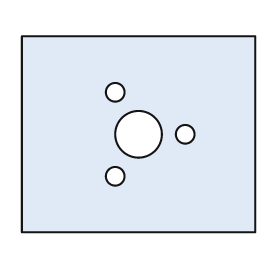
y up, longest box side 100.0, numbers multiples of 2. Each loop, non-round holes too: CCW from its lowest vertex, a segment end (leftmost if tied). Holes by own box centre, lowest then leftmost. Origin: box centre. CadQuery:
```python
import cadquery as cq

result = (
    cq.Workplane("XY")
    .moveTo(-50.0, -42.0)
    .lineTo(50.0, -42.0)
    .lineTo(50.0, 42.0)
    .lineTo(-50.0, 42.0)
    .close()
    .moveTo(-10.0, -18.0)
    .circle(4.0)
    .moveTo(0.0, 0.0)
    .circle(10.0)
    .moveTo(20.0, 0.0)
    .circle(4.0)
    .moveTo(-10.0, 18.0)
    .circle(4.0)
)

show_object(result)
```